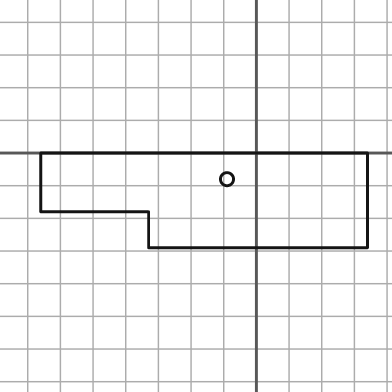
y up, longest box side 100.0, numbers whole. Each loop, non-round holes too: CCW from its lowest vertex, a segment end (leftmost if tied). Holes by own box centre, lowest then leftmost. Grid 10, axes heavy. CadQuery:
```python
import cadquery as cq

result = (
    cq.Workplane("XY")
    .moveTo(-33.0, -29.0)
    .lineTo(34.0, -29.0)
    .lineTo(34.0, 0.0)
    .lineTo(-66.0, 0.0)
    .lineTo(-66.0, -18.0)
    .lineTo(-33.0, -18.0)
    .close()
    .moveTo(-9.0, -8.0)
    .circle(2.0)
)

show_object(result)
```